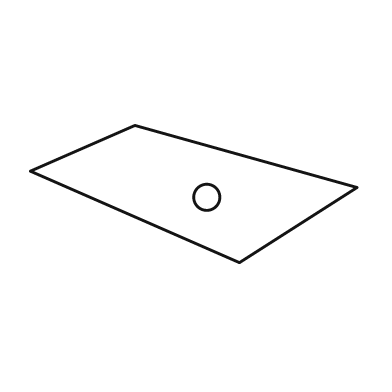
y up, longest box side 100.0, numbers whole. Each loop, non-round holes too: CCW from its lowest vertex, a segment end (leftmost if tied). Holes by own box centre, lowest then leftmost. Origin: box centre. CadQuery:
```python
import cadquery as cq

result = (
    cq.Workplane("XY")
    .moveTo(14.0, -21.0)
    .lineTo(50.0, 2.0)
    .lineTo(-18.0, 21.0)
    .lineTo(-50.0, 7.0)
    .close()
    .moveTo(4.0, -1.0)
    .circle(4.0)
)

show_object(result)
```